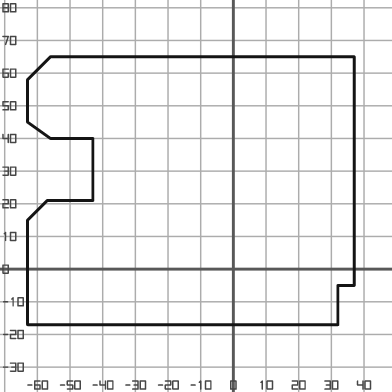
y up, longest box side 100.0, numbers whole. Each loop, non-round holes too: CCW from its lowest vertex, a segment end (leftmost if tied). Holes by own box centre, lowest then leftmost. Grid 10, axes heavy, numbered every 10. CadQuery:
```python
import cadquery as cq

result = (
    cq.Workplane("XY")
    .moveTo(-63.0, -17.0)
    .lineTo(32.0, -17.0)
    .lineTo(32.0, -5.0)
    .lineTo(37.0, -5.0)
    .lineTo(37.0, 65.0)
    .lineTo(-56.0, 65.0)
    .lineTo(-63.0, 58.0)
    .lineTo(-63.0, 45.0)
    .lineTo(-56.0, 40.0)
    .lineTo(-43.0, 40.0)
    .lineTo(-43.0, 21.0)
    .lineTo(-57.0, 21.0)
    .lineTo(-63.0, 15.0)
    .close()
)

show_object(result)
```